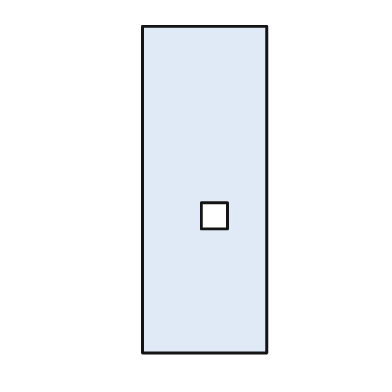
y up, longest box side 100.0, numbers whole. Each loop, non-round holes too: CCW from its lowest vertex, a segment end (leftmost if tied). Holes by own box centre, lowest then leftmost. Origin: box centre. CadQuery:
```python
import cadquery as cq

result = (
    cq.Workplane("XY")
    .moveTo(-19.0, -50.0)
    .lineTo(19.0, -50.0)
    .lineTo(19.0, 50.0)
    .lineTo(-19.0, 50.0)
    .close()
    .moveTo(-1.0, -12.0)
    .lineTo(7.0, -12.0)
    .lineTo(7.0, -4.0)
    .lineTo(-1.0, -4.0)
    .close()
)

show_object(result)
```